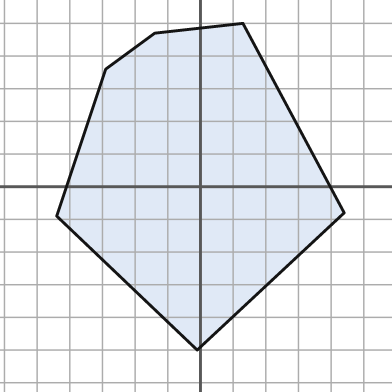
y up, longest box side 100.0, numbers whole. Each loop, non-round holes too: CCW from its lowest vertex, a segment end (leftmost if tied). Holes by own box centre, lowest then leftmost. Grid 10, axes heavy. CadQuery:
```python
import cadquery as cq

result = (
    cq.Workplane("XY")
    .moveTo(-1.0, -50.0)
    .lineTo(44.0, -8.0)
    .lineTo(13.0, 50.0)
    .lineTo(-14.0, 47.0)
    .lineTo(-29.0, 36.0)
    .lineTo(-44.0, -9.0)
    .close()
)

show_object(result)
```